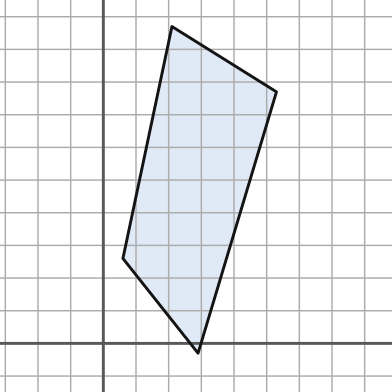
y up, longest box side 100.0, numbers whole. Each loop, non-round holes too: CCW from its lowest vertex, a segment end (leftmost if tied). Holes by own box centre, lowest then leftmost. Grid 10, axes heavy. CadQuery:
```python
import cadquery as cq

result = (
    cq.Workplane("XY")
    .moveTo(29.0, -3.0)
    .lineTo(53.0, 77.0)
    .lineTo(21.0, 97.0)
    .lineTo(6.0, 26.0)
    .close()
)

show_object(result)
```